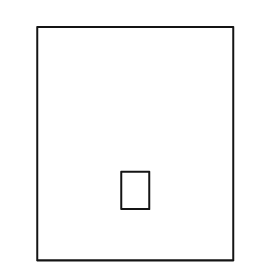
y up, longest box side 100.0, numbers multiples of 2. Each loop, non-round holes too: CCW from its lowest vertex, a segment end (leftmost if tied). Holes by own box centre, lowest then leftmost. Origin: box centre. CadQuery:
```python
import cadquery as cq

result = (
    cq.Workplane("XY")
    .moveTo(-42.0, -50.0)
    .lineTo(42.0, -50.0)
    .lineTo(42.0, 50.0)
    .lineTo(-42.0, 50.0)
    .close()
    .moveTo(-6.0, -28.0)
    .lineTo(6.0, -28.0)
    .lineTo(6.0, -12.0)
    .lineTo(-6.0, -12.0)
    .close()
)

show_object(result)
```